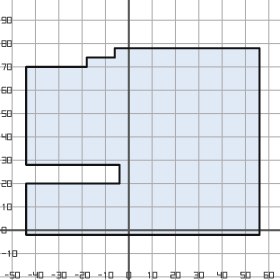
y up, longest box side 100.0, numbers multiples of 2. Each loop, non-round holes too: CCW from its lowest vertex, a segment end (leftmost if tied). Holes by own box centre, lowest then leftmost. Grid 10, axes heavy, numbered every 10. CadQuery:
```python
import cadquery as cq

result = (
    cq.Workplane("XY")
    .moveTo(-44.0, -2.0)
    .lineTo(56.0, -2.0)
    .lineTo(56.0, 78.0)
    .lineTo(-6.0, 78.0)
    .lineTo(-6.0, 74.0)
    .lineTo(-18.0, 74.0)
    .lineTo(-18.0, 70.0)
    .lineTo(-44.0, 70.0)
    .lineTo(-44.0, 28.0)
    .lineTo(-4.0, 28.0)
    .lineTo(-4.0, 20.0)
    .lineTo(-44.0, 20.0)
    .close()
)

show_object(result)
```